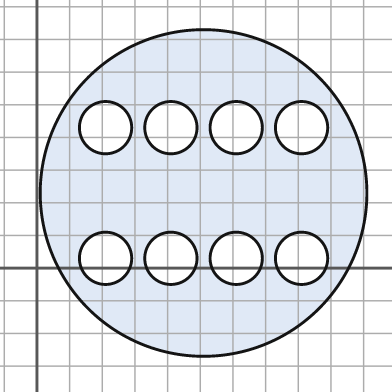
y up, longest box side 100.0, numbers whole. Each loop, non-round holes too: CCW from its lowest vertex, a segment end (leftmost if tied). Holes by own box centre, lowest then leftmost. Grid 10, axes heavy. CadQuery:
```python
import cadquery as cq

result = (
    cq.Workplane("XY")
    .moveTo(51.0, 23.0)
    .circle(50.0)
    .moveTo(21.0, 3.0)
    .circle(8.0)
    .moveTo(41.0, 3.0)
    .circle(8.0)
    .moveTo(61.0, 3.0)
    .circle(8.0)
    .moveTo(81.0, 3.0)
    .circle(8.0)
    .moveTo(21.0, 43.0)
    .circle(8.0)
    .moveTo(41.0, 43.0)
    .circle(8.0)
    .moveTo(61.0, 43.0)
    .circle(8.0)
    .moveTo(81.0, 43.0)
    .circle(8.0)
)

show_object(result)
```